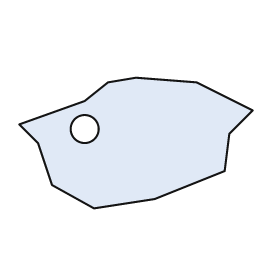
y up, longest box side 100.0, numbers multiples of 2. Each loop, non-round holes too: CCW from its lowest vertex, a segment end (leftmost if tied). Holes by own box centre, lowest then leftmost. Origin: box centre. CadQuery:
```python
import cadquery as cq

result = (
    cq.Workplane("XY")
    .moveTo(-18.0, -28.0)
    .lineTo(8.0, -24.0)
    .lineTo(38.0, -12.0)
    .lineTo(40.0, 4.0)
    .lineTo(50.0, 14.0)
    .lineTo(26.0, 26.0)
    .lineTo(0.0, 28.0)
    .lineTo(-12.0, 26.0)
    .lineTo(-22.0, 18.0)
    .lineTo(-50.0, 8.0)
    .lineTo(-42.0, 0.0)
    .lineTo(-36.0, -18.0)
    .close()
    .moveTo(-22.0, 6.0)
    .circle(6.0)
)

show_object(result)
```